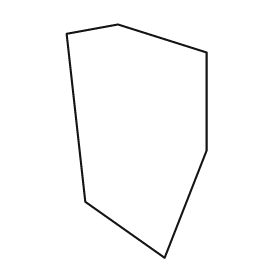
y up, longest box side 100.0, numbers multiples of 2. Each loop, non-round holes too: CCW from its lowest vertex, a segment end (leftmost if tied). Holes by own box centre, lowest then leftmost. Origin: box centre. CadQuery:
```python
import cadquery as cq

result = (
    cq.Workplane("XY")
    .moveTo(12.0, -50.0)
    .lineTo(30.0, -4.0)
    .lineTo(30.0, 38.0)
    .lineTo(-8.0, 50.0)
    .lineTo(-30.0, 46.0)
    .lineTo(-22.0, -26.0)
    .close()
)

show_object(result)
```